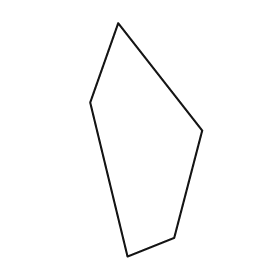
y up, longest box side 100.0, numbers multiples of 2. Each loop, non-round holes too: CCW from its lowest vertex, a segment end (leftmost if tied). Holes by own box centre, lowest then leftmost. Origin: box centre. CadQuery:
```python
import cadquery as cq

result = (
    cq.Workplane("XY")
    .moveTo(-8.0, -50.0)
    .lineTo(12.0, -42.0)
    .lineTo(24.0, 4.0)
    .lineTo(-12.0, 50.0)
    .lineTo(-24.0, 16.0)
    .close()
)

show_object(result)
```